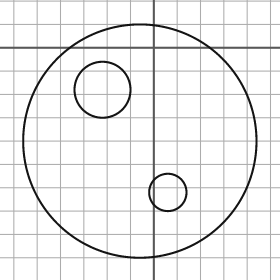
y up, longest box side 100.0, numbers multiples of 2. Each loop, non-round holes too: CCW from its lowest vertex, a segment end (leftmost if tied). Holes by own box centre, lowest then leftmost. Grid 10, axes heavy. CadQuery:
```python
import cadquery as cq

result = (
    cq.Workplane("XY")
    .moveTo(-6.0, -40.0)
    .circle(50.0)
    .moveTo(6.0, -62.0)
    .circle(8.0)
    .moveTo(-22.0, -18.0)
    .circle(12.0)
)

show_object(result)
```